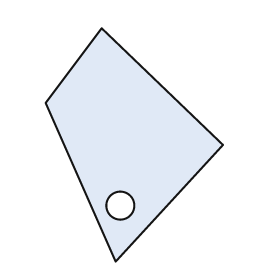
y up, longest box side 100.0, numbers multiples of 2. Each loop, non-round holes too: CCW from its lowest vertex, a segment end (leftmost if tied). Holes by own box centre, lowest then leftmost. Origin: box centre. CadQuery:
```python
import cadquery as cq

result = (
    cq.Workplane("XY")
    .moveTo(-8.0, -50.0)
    .lineTo(38.0, 0.0)
    .lineTo(-14.0, 50.0)
    .lineTo(-38.0, 18.0)
    .close()
    .moveTo(-6.0, -26.0)
    .circle(6.0)
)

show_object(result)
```